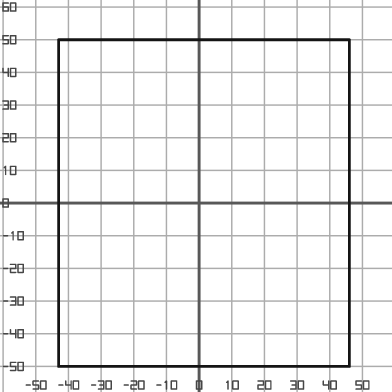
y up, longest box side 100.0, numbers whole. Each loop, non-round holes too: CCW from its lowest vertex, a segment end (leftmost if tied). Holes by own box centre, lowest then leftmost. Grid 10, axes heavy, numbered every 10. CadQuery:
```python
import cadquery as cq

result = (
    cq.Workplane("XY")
    .moveTo(-43.0, -50.0)
    .lineTo(46.0, -50.0)
    .lineTo(46.0, 50.0)
    .lineTo(-43.0, 50.0)
    .close()
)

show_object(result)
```